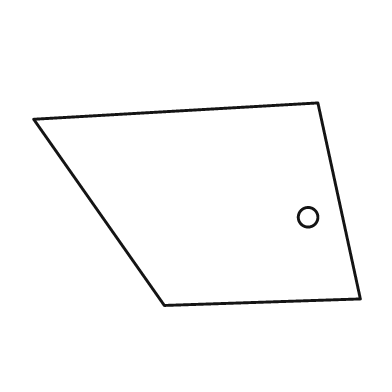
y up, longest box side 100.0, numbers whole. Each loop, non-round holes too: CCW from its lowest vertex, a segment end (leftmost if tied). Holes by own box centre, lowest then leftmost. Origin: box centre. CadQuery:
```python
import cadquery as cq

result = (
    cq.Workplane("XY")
    .moveTo(-10.0, -31.0)
    .lineTo(50.0, -29.0)
    .lineTo(37.0, 31.0)
    .lineTo(-50.0, 26.0)
    .close()
    .moveTo(34.0, -4.0)
    .circle(3.0)
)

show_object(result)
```